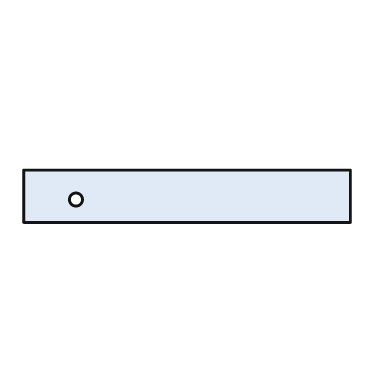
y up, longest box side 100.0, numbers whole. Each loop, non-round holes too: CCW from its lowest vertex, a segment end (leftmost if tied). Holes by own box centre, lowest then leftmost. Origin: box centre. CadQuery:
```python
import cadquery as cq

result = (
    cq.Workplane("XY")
    .moveTo(-50.0, -8.0)
    .lineTo(50.0, -8.0)
    .lineTo(50.0, 8.0)
    .lineTo(-50.0, 8.0)
    .close()
    .moveTo(-34.0, -1.0)
    .circle(2.0)
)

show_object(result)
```